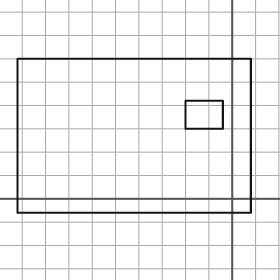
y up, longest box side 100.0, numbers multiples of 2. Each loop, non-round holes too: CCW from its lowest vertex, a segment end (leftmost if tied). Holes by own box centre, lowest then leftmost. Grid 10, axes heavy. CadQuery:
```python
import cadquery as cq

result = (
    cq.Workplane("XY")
    .moveTo(-92.0, -6.0)
    .lineTo(8.0, -6.0)
    .lineTo(8.0, 60.0)
    .lineTo(-92.0, 60.0)
    .close()
    .moveTo(-20.0, 30.0)
    .lineTo(-4.0, 30.0)
    .lineTo(-4.0, 42.0)
    .lineTo(-20.0, 42.0)
    .close()
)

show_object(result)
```